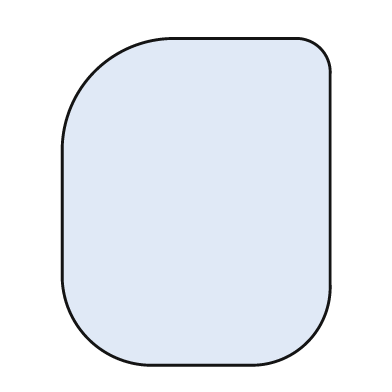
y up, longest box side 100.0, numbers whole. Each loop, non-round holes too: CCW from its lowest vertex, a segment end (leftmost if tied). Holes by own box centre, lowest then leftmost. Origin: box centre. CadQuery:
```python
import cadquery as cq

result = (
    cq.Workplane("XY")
    .moveTo(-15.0, -50.0)
    .lineTo(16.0, -50.0)
    .threePointArc((34.0, -43.0), (41.0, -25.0))
    .lineTo(41.0, 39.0)
    .threePointArc((38.0, 47.0), (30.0, 50.0))
    .lineTo(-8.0, 50.0)
    .threePointArc((-31.0, 40.0), (-41.0, 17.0))
    .lineTo(-41.0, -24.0)
    .threePointArc((-33.0, -42.0), (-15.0, -50.0))
    .close()
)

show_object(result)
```